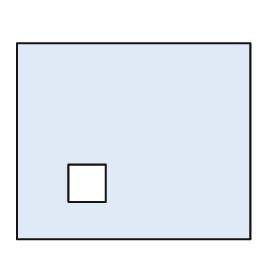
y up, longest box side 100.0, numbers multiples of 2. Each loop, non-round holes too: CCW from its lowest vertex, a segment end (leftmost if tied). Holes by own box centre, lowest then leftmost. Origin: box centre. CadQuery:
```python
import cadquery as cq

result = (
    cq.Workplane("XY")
    .moveTo(-50.0, -42.0)
    .lineTo(50.0, -42.0)
    .lineTo(50.0, 42.0)
    .lineTo(-50.0, 42.0)
    .close()
    .moveTo(-28.0, -26.0)
    .lineTo(-12.0, -26.0)
    .lineTo(-12.0, -10.0)
    .lineTo(-28.0, -10.0)
    .close()
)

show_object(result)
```